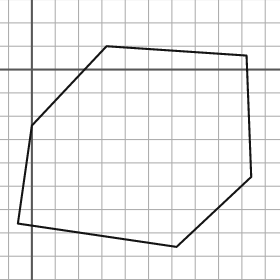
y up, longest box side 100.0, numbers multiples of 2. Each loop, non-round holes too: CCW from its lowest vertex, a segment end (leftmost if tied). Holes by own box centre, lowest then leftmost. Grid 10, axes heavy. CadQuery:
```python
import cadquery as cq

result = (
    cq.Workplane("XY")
    .moveTo(62.0, -76.0)
    .lineTo(94.0, -46.0)
    .lineTo(92.0, 6.0)
    .lineTo(32.0, 10.0)
    .lineTo(0.0, -24.0)
    .lineTo(-6.0, -66.0)
    .close()
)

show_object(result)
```